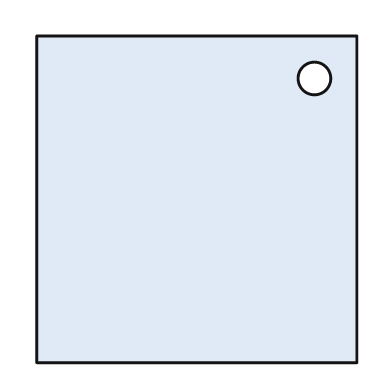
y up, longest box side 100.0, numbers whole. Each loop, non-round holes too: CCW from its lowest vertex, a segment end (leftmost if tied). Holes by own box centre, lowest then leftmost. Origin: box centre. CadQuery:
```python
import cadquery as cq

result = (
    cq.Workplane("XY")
    .moveTo(-49.0, -50.0)
    .lineTo(49.0, -50.0)
    .lineTo(49.0, 50.0)
    .lineTo(-49.0, 50.0)
    .close()
    .moveTo(36.0, 37.0)
    .circle(5.0)
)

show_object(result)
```